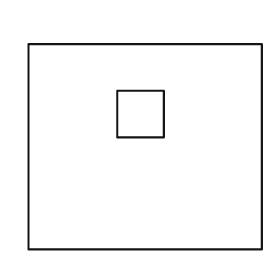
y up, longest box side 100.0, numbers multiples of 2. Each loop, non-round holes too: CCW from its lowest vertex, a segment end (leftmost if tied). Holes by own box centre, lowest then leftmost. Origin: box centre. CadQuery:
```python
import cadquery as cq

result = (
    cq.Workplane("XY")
    .moveTo(-50.0, -44.0)
    .lineTo(50.0, -44.0)
    .lineTo(50.0, 44.0)
    .lineTo(-50.0, 44.0)
    .close()
    .moveTo(-12.0, 4.0)
    .lineTo(8.0, 4.0)
    .lineTo(8.0, 24.0)
    .lineTo(-12.0, 24.0)
    .close()
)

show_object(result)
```